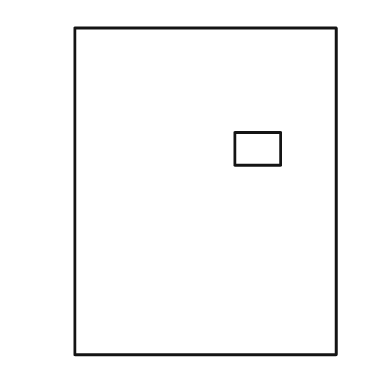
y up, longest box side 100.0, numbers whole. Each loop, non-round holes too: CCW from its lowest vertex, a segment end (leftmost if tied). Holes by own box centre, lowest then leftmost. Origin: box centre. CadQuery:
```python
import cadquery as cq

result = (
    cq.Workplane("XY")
    .moveTo(-40.0, -50.0)
    .lineTo(40.0, -50.0)
    .lineTo(40.0, 50.0)
    .lineTo(-40.0, 50.0)
    .close()
    .moveTo(9.0, 8.0)
    .lineTo(23.0, 8.0)
    .lineTo(23.0, 18.0)
    .lineTo(9.0, 18.0)
    .close()
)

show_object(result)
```